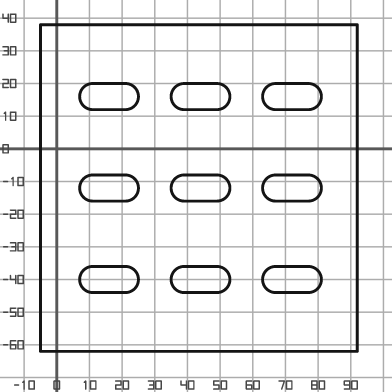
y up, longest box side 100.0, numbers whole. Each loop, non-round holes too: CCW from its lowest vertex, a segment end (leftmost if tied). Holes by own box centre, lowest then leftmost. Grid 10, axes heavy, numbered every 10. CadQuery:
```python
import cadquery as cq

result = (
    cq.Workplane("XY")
    .moveTo(-5.0, -62.0)
    .lineTo(92.0, -62.0)
    .lineTo(92.0, 38.0)
    .lineTo(-5.0, 38.0)
    .close()
    .moveTo(11.0, -44.0)
    .lineTo(21.0, -44.0)
    .threePointArc((25.0, -40.0), (21.0, -36.0))
    .lineTo(11.0, -36.0)
    .threePointArc((7.0, -40.0), (11.0, -44.0))
    .close()
    .moveTo(39.0, -44.0)
    .lineTo(49.0, -44.0)
    .threePointArc((53.0, -40.0), (49.0, -36.0))
    .lineTo(39.0, -36.0)
    .threePointArc((35.0, -40.0), (39.0, -44.0))
    .close()
    .moveTo(67.0, -44.0)
    .lineTo(77.0, -44.0)
    .threePointArc((81.0, -40.0), (77.0, -36.0))
    .lineTo(67.0, -36.0)
    .threePointArc((63.0, -40.0), (67.0, -44.0))
    .close()
    .moveTo(11.0, -16.0)
    .lineTo(21.0, -16.0)
    .threePointArc((25.0, -12.0), (21.0, -8.0))
    .lineTo(11.0, -8.0)
    .threePointArc((7.0, -12.0), (11.0, -16.0))
    .close()
    .moveTo(39.0, -16.0)
    .lineTo(49.0, -16.0)
    .threePointArc((53.0, -12.0), (49.0, -8.0))
    .lineTo(39.0, -8.0)
    .threePointArc((35.0, -12.0), (39.0, -16.0))
    .close()
    .moveTo(67.0, -16.0)
    .lineTo(77.0, -16.0)
    .threePointArc((81.0, -12.0), (77.0, -8.0))
    .lineTo(67.0, -8.0)
    .threePointArc((63.0, -12.0), (67.0, -16.0))
    .close()
    .moveTo(11.0, 12.0)
    .lineTo(21.0, 12.0)
    .threePointArc((25.0, 16.0), (21.0, 20.0))
    .lineTo(11.0, 20.0)
    .threePointArc((7.0, 16.0), (11.0, 12.0))
    .close()
    .moveTo(39.0, 12.0)
    .lineTo(49.0, 12.0)
    .threePointArc((53.0, 16.0), (49.0, 20.0))
    .lineTo(39.0, 20.0)
    .threePointArc((35.0, 16.0), (39.0, 12.0))
    .close()
    .moveTo(67.0, 12.0)
    .lineTo(77.0, 12.0)
    .threePointArc((81.0, 16.0), (77.0, 20.0))
    .lineTo(67.0, 20.0)
    .threePointArc((63.0, 16.0), (67.0, 12.0))
    .close()
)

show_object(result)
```